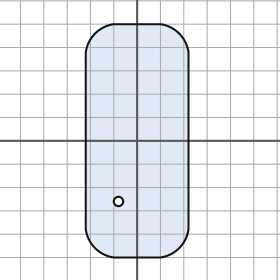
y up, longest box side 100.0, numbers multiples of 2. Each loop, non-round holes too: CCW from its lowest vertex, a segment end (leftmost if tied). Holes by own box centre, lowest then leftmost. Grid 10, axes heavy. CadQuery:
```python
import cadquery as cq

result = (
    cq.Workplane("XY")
    .moveTo(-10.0, -50.0)
    .lineTo(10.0, -50.0)
    .threePointArc((18.0, -46.0), (22.0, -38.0))
    .lineTo(22.0, 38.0)
    .threePointArc((18.0, 46.0), (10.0, 50.0))
    .lineTo(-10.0, 50.0)
    .threePointArc((-18.0, 46.0), (-22.0, 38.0))
    .lineTo(-22.0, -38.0)
    .threePointArc((-18.0, -46.0), (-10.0, -50.0))
    .close()
    .moveTo(-8.0, -26.0)
    .circle(2.0)
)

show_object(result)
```